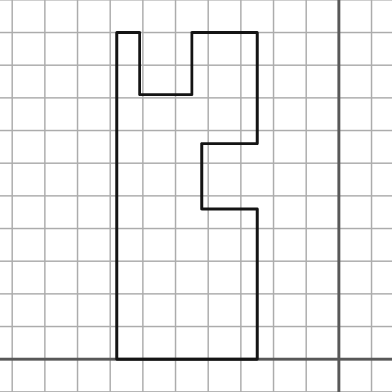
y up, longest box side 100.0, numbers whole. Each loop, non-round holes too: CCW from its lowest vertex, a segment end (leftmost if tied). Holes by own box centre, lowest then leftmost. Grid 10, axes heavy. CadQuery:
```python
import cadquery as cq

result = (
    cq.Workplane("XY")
    .moveTo(-68.0, 0.0)
    .lineTo(-25.0, 0.0)
    .lineTo(-25.0, 46.0)
    .lineTo(-42.0, 46.0)
    .lineTo(-42.0, 66.0)
    .lineTo(-25.0, 66.0)
    .lineTo(-25.0, 100.0)
    .lineTo(-45.0, 100.0)
    .lineTo(-45.0, 81.0)
    .lineTo(-61.0, 81.0)
    .lineTo(-61.0, 100.0)
    .lineTo(-68.0, 100.0)
    .close()
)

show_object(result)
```